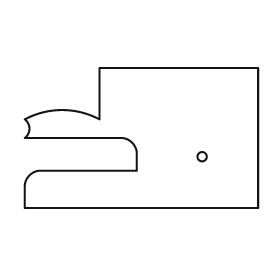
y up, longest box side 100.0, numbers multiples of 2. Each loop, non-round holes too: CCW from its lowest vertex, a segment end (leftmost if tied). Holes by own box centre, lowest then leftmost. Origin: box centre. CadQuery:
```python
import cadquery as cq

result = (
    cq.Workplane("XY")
    .moveTo(-50.0, -30.0)
    .lineTo(50.0, -30.0)
    .lineTo(50.0, 30.0)
    .lineTo(-18.0, 30.0)
    .lineTo(-18.0, 8.0)
    .threePointArc((-34.0, 12.0), (-50.0, 8.0))
    .threePointArc((-48.0, 4.0), (-50.0, 0.0))
    .lineTo(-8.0, 0.0)
    .threePointArc((-4.0, -2.0), (-2.0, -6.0))
    .lineTo(-2.0, -14.0)
    .lineTo(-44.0, -14.0)
    .threePointArc((-48.0, -16.0), (-50.0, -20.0))
    .close()
    .moveTo(26.0, -8.0)
    .circle(2.0)
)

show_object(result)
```